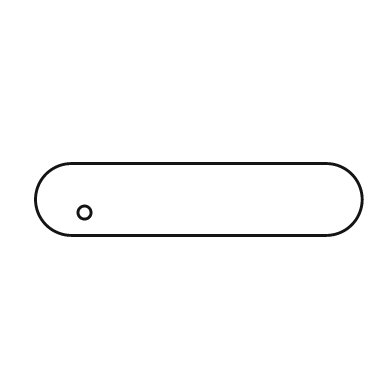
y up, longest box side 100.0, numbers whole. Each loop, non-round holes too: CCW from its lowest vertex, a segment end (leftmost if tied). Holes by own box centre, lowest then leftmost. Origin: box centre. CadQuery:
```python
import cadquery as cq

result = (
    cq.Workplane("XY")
    .moveTo(-39.0, -11.0)
    .lineTo(39.0, -11.0)
    .threePointArc((50.0, 0.0), (39.0, 11.0))
    .lineTo(-39.0, 11.0)
    .threePointArc((-50.0, 0.0), (-39.0, -11.0))
    .close()
    .moveTo(-35.0, -4.0)
    .circle(2.0)
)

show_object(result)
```